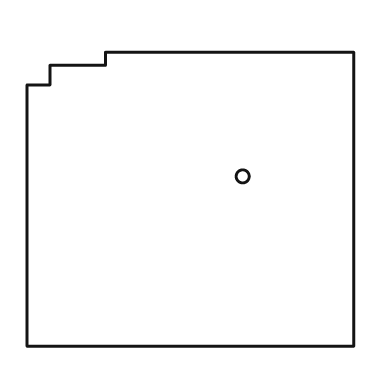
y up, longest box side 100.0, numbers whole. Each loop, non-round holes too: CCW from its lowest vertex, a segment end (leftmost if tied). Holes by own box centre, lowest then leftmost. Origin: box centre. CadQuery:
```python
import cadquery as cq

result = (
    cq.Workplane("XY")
    .moveTo(-50.0, -45.0)
    .lineTo(50.0, -45.0)
    .lineTo(50.0, 45.0)
    .lineTo(-26.0, 45.0)
    .lineTo(-26.0, 41.0)
    .lineTo(-43.0, 41.0)
    .lineTo(-43.0, 35.0)
    .lineTo(-50.0, 35.0)
    .close()
    .moveTo(16.0, 7.0)
    .circle(2.0)
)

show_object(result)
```